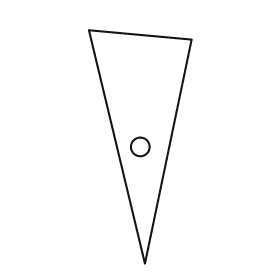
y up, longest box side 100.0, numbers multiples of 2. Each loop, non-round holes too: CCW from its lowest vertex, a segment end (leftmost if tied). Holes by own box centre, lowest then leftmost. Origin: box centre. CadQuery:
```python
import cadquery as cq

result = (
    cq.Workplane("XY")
    .moveTo(2.0, -50.0)
    .lineTo(22.0, 46.0)
    .lineTo(-22.0, 50.0)
    .close()
    .moveTo(0.0, 0.0)
    .circle(4.0)
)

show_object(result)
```